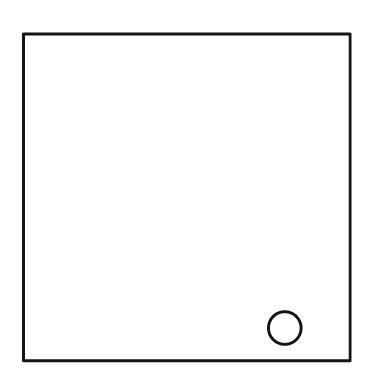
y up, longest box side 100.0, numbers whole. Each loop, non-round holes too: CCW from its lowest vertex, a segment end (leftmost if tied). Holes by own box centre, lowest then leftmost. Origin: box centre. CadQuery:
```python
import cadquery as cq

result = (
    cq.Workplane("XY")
    .moveTo(-50.0, -50.0)
    .lineTo(50.0, -50.0)
    .lineTo(50.0, 50.0)
    .lineTo(-50.0, 50.0)
    .close()
    .moveTo(30.0, -40.0)
    .circle(5.0)
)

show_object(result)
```